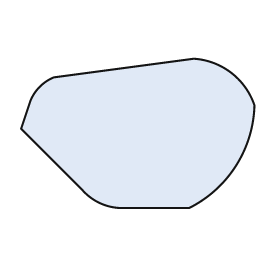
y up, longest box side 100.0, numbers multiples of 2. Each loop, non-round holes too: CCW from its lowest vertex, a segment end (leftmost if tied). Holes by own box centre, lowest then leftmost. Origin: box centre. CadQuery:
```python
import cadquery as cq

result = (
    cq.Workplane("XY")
    .moveTo(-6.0, -32.0)
    .lineTo(22.0, -32.0)
    .threePointArc((42.0, -14.0), (50.0, 12.0))
    .threePointArc((40.0, 26.0), (24.0, 32.0))
    .lineTo(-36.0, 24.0)
    .threePointArc((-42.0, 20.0), (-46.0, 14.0))
    .lineTo(-50.0, 2.0)
    .lineTo(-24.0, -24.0)
    .threePointArc((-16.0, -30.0), (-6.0, -32.0))
    .close()
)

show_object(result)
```